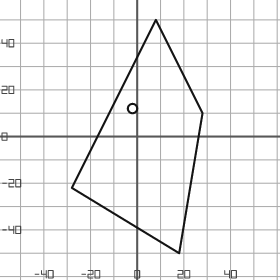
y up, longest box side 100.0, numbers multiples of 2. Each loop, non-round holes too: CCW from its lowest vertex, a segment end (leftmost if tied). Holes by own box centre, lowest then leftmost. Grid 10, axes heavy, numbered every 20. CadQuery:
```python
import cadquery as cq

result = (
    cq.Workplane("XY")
    .moveTo(18.0, -50.0)
    .lineTo(28.0, 10.0)
    .lineTo(8.0, 50.0)
    .lineTo(-28.0, -22.0)
    .close()
    .moveTo(-2.0, 12.0)
    .circle(2.0)
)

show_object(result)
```